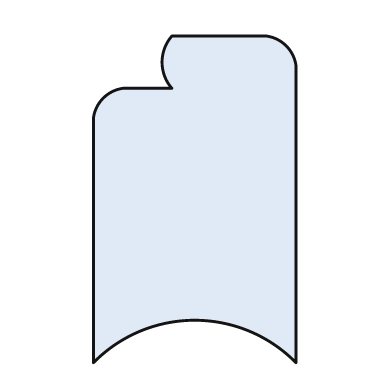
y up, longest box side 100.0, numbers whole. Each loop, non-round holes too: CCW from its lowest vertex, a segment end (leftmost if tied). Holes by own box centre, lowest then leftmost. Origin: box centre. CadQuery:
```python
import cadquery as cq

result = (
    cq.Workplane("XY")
    .moveTo(-31.0, -50.0)
    .threePointArc((0.0, -37.0), (31.0, -50.0))
    .lineTo(31.0, 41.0)
    .threePointArc((28.0, 47.0), (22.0, 50.0))
    .lineTo(-7.0, 50.0)
    .threePointArc((-10.0, 42.0), (-7.0, 34.0))
    .lineTo(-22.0, 34.0)
    .threePointArc((-28.0, 31.0), (-31.0, 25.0))
    .close()
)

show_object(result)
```